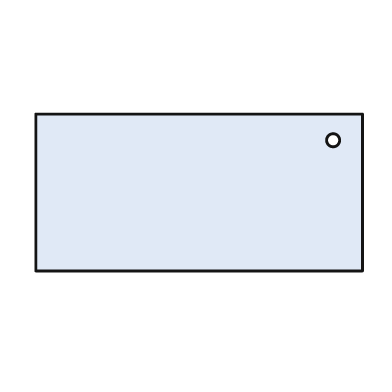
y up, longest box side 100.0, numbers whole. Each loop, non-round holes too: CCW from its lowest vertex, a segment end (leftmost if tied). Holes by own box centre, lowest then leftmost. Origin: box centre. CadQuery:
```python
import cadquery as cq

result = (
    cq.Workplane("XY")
    .moveTo(-50.0, -24.0)
    .lineTo(50.0, -24.0)
    .lineTo(50.0, 24.0)
    .lineTo(-50.0, 24.0)
    .close()
    .moveTo(41.0, 16.0)
    .circle(2.0)
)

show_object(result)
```